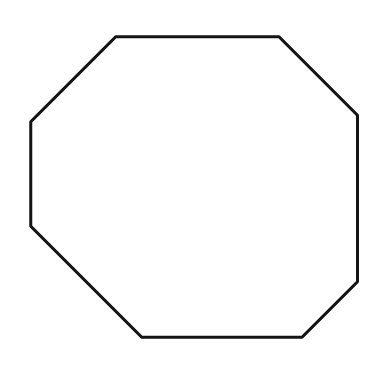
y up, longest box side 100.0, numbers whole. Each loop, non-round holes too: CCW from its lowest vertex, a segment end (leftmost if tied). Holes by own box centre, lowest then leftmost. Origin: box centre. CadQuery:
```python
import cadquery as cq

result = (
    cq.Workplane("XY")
    .moveTo(-16.0, -46.0)
    .lineTo(33.0, -46.0)
    .lineTo(50.0, -29.0)
    .lineTo(50.0, 22.0)
    .lineTo(26.0, 46.0)
    .lineTo(-24.0, 46.0)
    .lineTo(-50.0, 20.0)
    .lineTo(-50.0, -12.0)
    .close()
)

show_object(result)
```